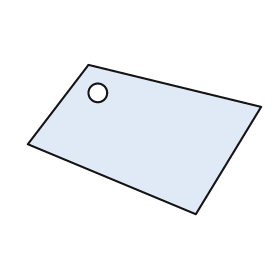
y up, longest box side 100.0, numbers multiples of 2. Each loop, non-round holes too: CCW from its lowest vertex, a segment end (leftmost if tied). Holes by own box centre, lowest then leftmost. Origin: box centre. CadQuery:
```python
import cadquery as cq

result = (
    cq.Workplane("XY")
    .moveTo(22.0, -32.0)
    .lineTo(50.0, 14.0)
    .lineTo(-24.0, 32.0)
    .lineTo(-50.0, -2.0)
    .close()
    .moveTo(-20.0, 20.0)
    .circle(4.0)
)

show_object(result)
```